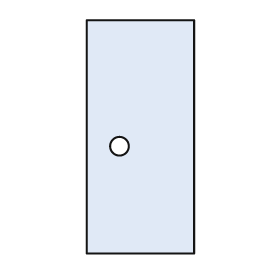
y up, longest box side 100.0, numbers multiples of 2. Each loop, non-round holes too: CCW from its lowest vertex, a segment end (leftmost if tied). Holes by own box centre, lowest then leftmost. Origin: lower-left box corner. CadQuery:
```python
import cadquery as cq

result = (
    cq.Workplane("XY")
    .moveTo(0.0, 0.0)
    .lineTo(46.0, 0.0)
    .lineTo(46.0, 100.0)
    .lineTo(0.0, 100.0)
    .close()
    .moveTo(14.0, 46.0)
    .circle(4.0)
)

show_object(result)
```